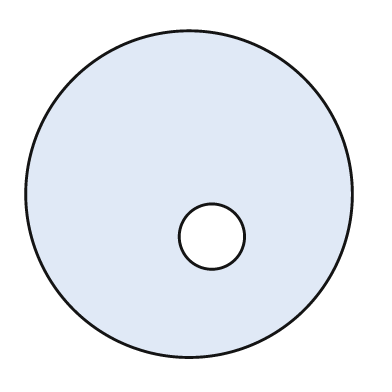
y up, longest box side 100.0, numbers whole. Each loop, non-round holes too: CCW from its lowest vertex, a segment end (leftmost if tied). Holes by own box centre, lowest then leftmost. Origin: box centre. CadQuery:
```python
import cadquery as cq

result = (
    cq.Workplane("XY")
    .moveTo(0.0, 0.0)
    .circle(50.0)
    .moveTo(7.0, -13.0)
    .circle(10.0)
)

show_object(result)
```